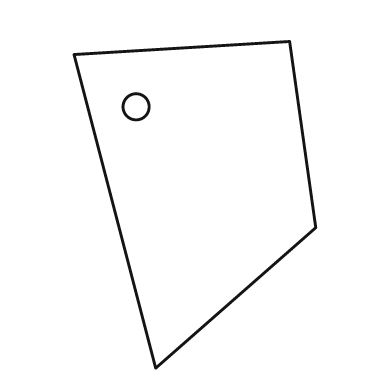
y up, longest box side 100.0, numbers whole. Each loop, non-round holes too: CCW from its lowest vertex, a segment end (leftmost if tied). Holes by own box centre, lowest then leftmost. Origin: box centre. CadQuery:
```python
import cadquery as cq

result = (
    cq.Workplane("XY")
    .moveTo(-12.0, -50.0)
    .lineTo(37.0, -7.0)
    .lineTo(29.0, 50.0)
    .lineTo(-37.0, 46.0)
    .close()
    .moveTo(-18.0, 30.0)
    .circle(4.0)
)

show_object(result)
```